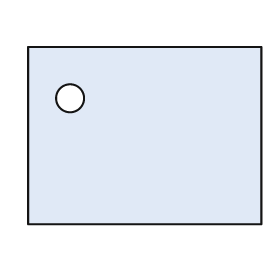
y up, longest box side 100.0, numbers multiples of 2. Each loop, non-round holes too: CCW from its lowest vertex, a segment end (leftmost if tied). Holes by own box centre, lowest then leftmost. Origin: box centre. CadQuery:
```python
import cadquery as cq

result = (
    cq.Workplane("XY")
    .moveTo(-50.0, -38.0)
    .lineTo(50.0, -38.0)
    .lineTo(50.0, 38.0)
    .lineTo(-50.0, 38.0)
    .close()
    .moveTo(-32.0, 16.0)
    .circle(6.0)
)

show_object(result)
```